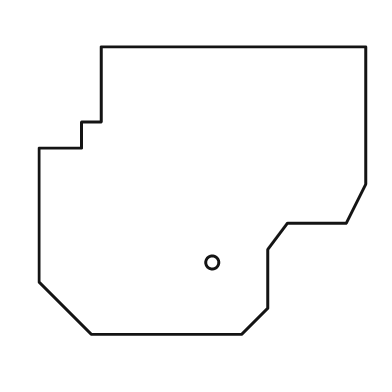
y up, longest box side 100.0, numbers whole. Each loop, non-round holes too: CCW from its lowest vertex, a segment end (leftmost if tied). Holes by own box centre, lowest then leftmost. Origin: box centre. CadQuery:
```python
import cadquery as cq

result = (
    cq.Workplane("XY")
    .moveTo(-34.0, -44.0)
    .lineTo(12.0, -44.0)
    .lineTo(20.0, -36.0)
    .lineTo(20.0, -18.0)
    .lineTo(26.0, -10.0)
    .lineTo(44.0, -10.0)
    .lineTo(50.0, 2.0)
    .lineTo(50.0, 44.0)
    .lineTo(-31.0, 44.0)
    .lineTo(-31.0, 21.0)
    .lineTo(-37.0, 21.0)
    .lineTo(-37.0, 13.0)
    .lineTo(-50.0, 13.0)
    .lineTo(-50.0, -28.0)
    .close()
    .moveTo(3.0, -22.0)
    .circle(2.0)
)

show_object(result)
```